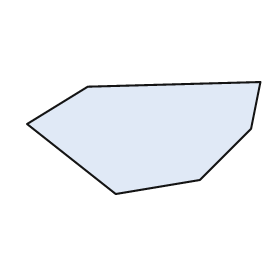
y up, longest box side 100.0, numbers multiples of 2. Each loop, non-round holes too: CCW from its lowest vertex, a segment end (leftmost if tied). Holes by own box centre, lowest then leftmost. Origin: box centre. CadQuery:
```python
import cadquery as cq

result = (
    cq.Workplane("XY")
    .moveTo(-12.0, -24.0)
    .lineTo(24.0, -18.0)
    .lineTo(46.0, 4.0)
    .lineTo(50.0, 24.0)
    .lineTo(-24.0, 22.0)
    .lineTo(-50.0, 6.0)
    .close()
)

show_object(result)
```